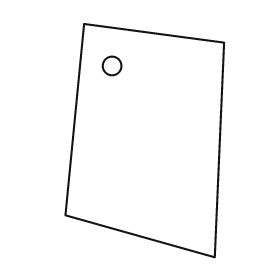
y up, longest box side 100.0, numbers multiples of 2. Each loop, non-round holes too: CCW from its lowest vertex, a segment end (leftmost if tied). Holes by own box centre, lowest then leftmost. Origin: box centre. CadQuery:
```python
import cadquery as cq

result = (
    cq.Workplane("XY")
    .moveTo(30.0, -50.0)
    .lineTo(34.0, 42.0)
    .lineTo(-26.0, 50.0)
    .lineTo(-34.0, -32.0)
    .close()
    .moveTo(-14.0, 32.0)
    .circle(4.0)
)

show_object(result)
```